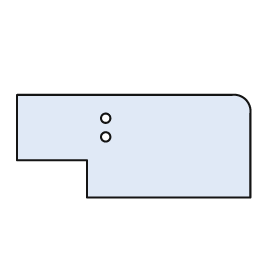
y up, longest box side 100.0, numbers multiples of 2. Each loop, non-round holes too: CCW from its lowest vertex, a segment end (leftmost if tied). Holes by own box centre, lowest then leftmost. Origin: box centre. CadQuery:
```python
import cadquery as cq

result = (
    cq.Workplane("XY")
    .moveTo(-20.0, -22.0)
    .lineTo(50.0, -22.0)
    .lineTo(50.0, 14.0)
    .threePointArc((48.0, 20.0), (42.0, 22.0))
    .lineTo(-50.0, 22.0)
    .lineTo(-50.0, -6.0)
    .lineTo(-20.0, -6.0)
    .close()
    .moveTo(-12.0, 4.0)
    .circle(2.0)
    .moveTo(-12.0, 12.0)
    .circle(2.0)
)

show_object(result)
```